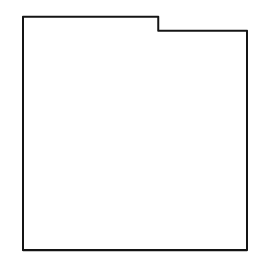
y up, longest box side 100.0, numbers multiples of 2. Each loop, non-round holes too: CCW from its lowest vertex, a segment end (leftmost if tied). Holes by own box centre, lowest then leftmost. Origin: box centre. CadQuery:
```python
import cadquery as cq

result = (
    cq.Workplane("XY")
    .moveTo(-48.0, -50.0)
    .lineTo(48.0, -50.0)
    .lineTo(48.0, 44.0)
    .lineTo(10.0, 44.0)
    .lineTo(10.0, 50.0)
    .lineTo(-48.0, 50.0)
    .close()
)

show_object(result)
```